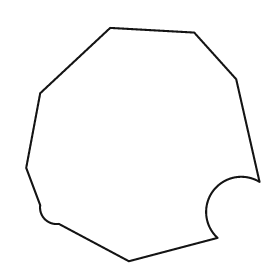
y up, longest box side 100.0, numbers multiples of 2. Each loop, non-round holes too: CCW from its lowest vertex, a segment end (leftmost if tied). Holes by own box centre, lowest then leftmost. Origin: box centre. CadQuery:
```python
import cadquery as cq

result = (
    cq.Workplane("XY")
    .moveTo(-6.0, -50.0)
    .lineTo(32.0, -40.0)
    .threePointArc((30.0, -20.0), (50.0, -16.0))
    .lineTo(40.0, 28.0)
    .lineTo(22.0, 48.0)
    .lineTo(-14.0, 50.0)
    .lineTo(-44.0, 22.0)
    .lineTo(-50.0, -10.0)
    .lineTo(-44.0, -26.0)
    .threePointArc((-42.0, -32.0), (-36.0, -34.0))
    .close()
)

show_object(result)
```